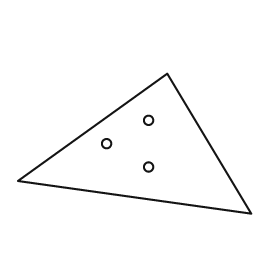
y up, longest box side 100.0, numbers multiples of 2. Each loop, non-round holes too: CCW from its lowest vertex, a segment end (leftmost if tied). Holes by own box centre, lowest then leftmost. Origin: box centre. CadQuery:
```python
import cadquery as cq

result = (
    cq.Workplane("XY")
    .moveTo(50.0, -30.0)
    .lineTo(14.0, 30.0)
    .lineTo(-50.0, -16.0)
    .close()
    .moveTo(6.0, -10.0)
    .circle(2.0)
    .moveTo(-12.0, 0.0)
    .circle(2.0)
    .moveTo(6.0, 10.0)
    .circle(2.0)
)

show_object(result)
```